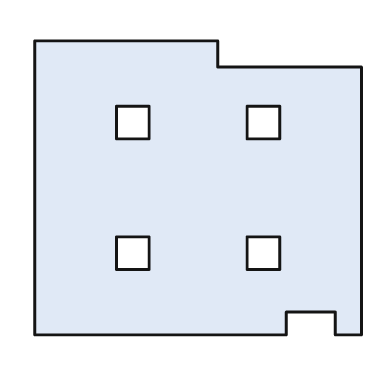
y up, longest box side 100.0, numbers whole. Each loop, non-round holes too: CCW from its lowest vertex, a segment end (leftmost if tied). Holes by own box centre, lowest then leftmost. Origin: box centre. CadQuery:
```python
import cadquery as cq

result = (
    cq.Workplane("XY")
    .moveTo(-50.0, -45.0)
    .lineTo(27.0, -45.0)
    .lineTo(27.0, -38.0)
    .lineTo(42.0, -38.0)
    .lineTo(42.0, -45.0)
    .lineTo(50.0, -45.0)
    .lineTo(50.0, 37.0)
    .lineTo(6.0, 37.0)
    .lineTo(6.0, 45.0)
    .lineTo(-50.0, 45.0)
    .close()
    .moveTo(-25.0, -25.0)
    .lineTo(-15.0, -25.0)
    .lineTo(-15.0, -15.0)
    .lineTo(-25.0, -15.0)
    .close()
    .moveTo(15.0, -25.0)
    .lineTo(25.0, -25.0)
    .lineTo(25.0, -15.0)
    .lineTo(15.0, -15.0)
    .close()
    .moveTo(-25.0, 15.0)
    .lineTo(-15.0, 15.0)
    .lineTo(-15.0, 25.0)
    .lineTo(-25.0, 25.0)
    .close()
    .moveTo(15.0, 15.0)
    .lineTo(25.0, 15.0)
    .lineTo(25.0, 25.0)
    .lineTo(15.0, 25.0)
    .close()
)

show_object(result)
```